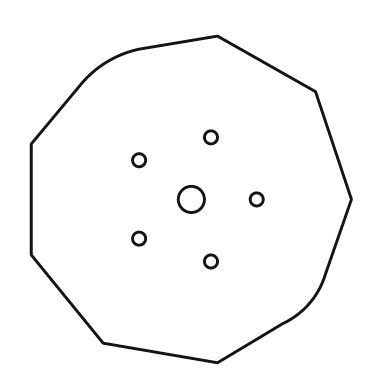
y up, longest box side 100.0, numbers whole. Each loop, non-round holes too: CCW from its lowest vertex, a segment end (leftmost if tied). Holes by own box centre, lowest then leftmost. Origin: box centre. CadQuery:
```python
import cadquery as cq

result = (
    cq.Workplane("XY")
    .moveTo(8.0, -50.0)
    .lineTo(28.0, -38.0)
    .threePointArc((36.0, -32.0), (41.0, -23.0))
    .lineTo(49.0, 0.0)
    .lineTo(38.0, 33.0)
    .lineTo(8.0, 50.0)
    .lineTo(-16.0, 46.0)
    .threePointArc((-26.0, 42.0), (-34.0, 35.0))
    .lineTo(-49.0, 17.0)
    .lineTo(-49.0, -17.0)
    .lineTo(-27.0, -44.0)
    .close()
    .moveTo(6.0, -19.0)
    .circle(2.0)
    .moveTo(-16.0, -12.0)
    .circle(2.0)
    .moveTo(0.0, 0.0)
    .circle(4.0)
    .moveTo(20.0, 0.0)
    .circle(2.0)
    .moveTo(-16.0, 12.0)
    .circle(2.0)
    .moveTo(6.0, 19.0)
    .circle(2.0)
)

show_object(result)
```